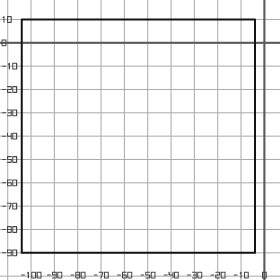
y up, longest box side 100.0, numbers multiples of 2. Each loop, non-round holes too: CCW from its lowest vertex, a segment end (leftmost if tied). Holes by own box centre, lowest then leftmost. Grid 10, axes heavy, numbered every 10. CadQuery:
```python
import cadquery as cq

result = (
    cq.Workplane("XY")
    .moveTo(-104.0, -90.0)
    .lineTo(-4.0, -90.0)
    .lineTo(-4.0, 10.0)
    .lineTo(-104.0, 10.0)
    .close()
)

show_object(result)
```